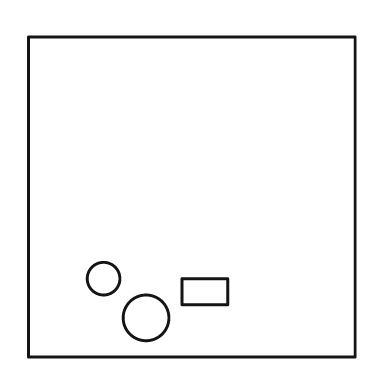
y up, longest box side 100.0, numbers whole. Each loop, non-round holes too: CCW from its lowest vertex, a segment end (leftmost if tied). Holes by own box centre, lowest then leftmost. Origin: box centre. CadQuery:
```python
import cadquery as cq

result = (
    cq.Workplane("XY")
    .moveTo(-50.0, -49.0)
    .lineTo(50.0, -49.0)
    .lineTo(50.0, 49.0)
    .lineTo(-50.0, 49.0)
    .close()
    .moveTo(-14.0, -37.0)
    .circle(7.0)
    .moveTo(-3.0, -33.0)
    .lineTo(11.0, -33.0)
    .lineTo(11.0, -25.0)
    .lineTo(-3.0, -25.0)
    .close()
    .moveTo(-27.0, -25.0)
    .circle(5.0)
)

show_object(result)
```